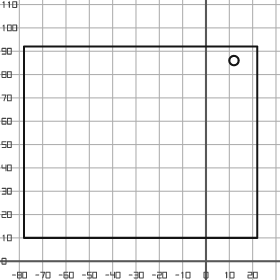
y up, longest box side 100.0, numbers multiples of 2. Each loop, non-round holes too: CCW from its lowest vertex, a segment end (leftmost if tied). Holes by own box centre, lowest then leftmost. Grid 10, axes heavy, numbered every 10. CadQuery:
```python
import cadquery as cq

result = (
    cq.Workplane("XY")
    .moveTo(-78.0, 10.0)
    .lineTo(22.0, 10.0)
    .lineTo(22.0, 92.0)
    .lineTo(-78.0, 92.0)
    .close()
    .moveTo(12.0, 86.0)
    .circle(2.0)
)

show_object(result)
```